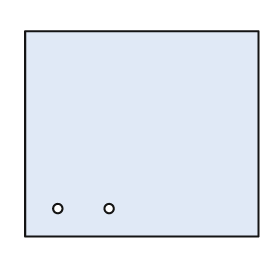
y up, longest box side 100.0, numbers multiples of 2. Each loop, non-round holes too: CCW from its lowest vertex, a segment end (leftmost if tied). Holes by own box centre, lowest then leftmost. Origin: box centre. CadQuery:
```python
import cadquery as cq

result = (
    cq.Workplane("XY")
    .moveTo(-50.0, -44.0)
    .lineTo(50.0, -44.0)
    .lineTo(50.0, 44.0)
    .lineTo(-50.0, 44.0)
    .close()
    .moveTo(-36.0, -32.0)
    .circle(2.0)
    .moveTo(-14.0, -32.0)
    .circle(2.0)
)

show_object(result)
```